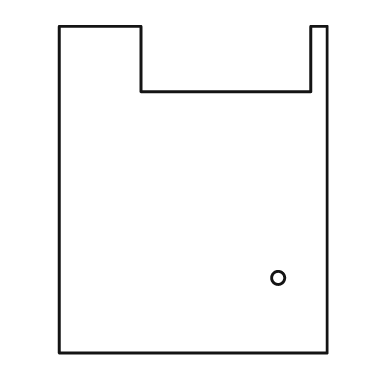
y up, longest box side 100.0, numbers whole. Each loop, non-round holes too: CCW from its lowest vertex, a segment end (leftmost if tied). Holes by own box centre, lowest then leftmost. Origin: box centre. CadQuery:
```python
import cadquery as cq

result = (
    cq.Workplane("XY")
    .moveTo(-41.0, -50.0)
    .lineTo(41.0, -50.0)
    .lineTo(41.0, 50.0)
    .lineTo(36.0, 50.0)
    .lineTo(36.0, 30.0)
    .lineTo(-16.0, 30.0)
    .lineTo(-16.0, 50.0)
    .lineTo(-41.0, 50.0)
    .close()
    .moveTo(26.0, -27.0)
    .circle(2.0)
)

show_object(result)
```